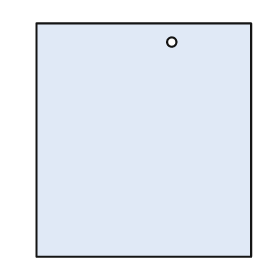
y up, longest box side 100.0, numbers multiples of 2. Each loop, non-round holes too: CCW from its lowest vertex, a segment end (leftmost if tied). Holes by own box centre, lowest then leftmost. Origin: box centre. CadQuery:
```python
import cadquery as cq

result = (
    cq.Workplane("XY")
    .moveTo(-46.0, -50.0)
    .lineTo(46.0, -50.0)
    .lineTo(46.0, 50.0)
    .lineTo(-46.0, 50.0)
    .close()
    .moveTo(12.0, 42.0)
    .circle(2.0)
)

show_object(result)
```